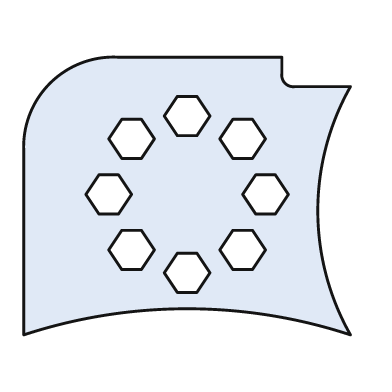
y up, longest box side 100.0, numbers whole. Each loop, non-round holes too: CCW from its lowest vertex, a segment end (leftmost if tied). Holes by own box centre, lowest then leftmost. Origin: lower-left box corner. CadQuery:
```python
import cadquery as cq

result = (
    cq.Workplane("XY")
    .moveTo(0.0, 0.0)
    .threePointArc((50.0, 8.0), (100.0, 0.0))
    .threePointArc((90.0, 38.0), (100.0, 76.0))
    .lineTo(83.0, 76.0)
    .threePointArc((80.0, 77.0), (79.0, 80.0))
    .lineTo(79.0, 85.0)
    .lineTo(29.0, 85.0)
    .threePointArc((8.0, 77.0), (0.0, 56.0))
    .close()
    .moveTo(47.0, 13.0)
    .lineTo(53.0, 13.0)
    .lineTo(57.0, 19.0)
    .lineTo(53.0, 25.0)
    .lineTo(47.0, 25.0)
    .lineTo(43.0, 19.0)
    .close()
    .moveTo(30.0, 20.0)
    .lineTo(36.0, 20.0)
    .lineTo(40.0, 26.0)
    .lineTo(36.0, 32.0)
    .lineTo(30.0, 32.0)
    .lineTo(26.0, 26.0)
    .close()
    .moveTo(64.0, 20.0)
    .lineTo(70.0, 20.0)
    .lineTo(74.0, 26.0)
    .lineTo(70.0, 32.0)
    .lineTo(64.0, 32.0)
    .lineTo(60.0, 26.0)
    .close()
    .moveTo(23.0, 37.0)
    .lineTo(29.0, 37.0)
    .lineTo(33.0, 43.0)
    .lineTo(29.0, 49.0)
    .lineTo(23.0, 49.0)
    .lineTo(19.0, 43.0)
    .close()
    .moveTo(71.0, 37.0)
    .lineTo(77.0, 37.0)
    .lineTo(81.0, 43.0)
    .lineTo(77.0, 49.0)
    .lineTo(71.0, 49.0)
    .lineTo(67.0, 43.0)
    .close()
    .moveTo(30.0, 54.0)
    .lineTo(36.0, 54.0)
    .lineTo(40.0, 60.0)
    .lineTo(36.0, 66.0)
    .lineTo(30.0, 66.0)
    .lineTo(26.0, 60.0)
    .close()
    .moveTo(64.0, 54.0)
    .lineTo(70.0, 54.0)
    .lineTo(74.0, 60.0)
    .lineTo(70.0, 66.0)
    .lineTo(64.0, 66.0)
    .lineTo(60.0, 60.0)
    .close()
    .moveTo(47.0, 61.0)
    .lineTo(53.0, 61.0)
    .lineTo(57.0, 67.0)
    .lineTo(53.0, 73.0)
    .lineTo(47.0, 73.0)
    .lineTo(43.0, 67.0)
    .close()
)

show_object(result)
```